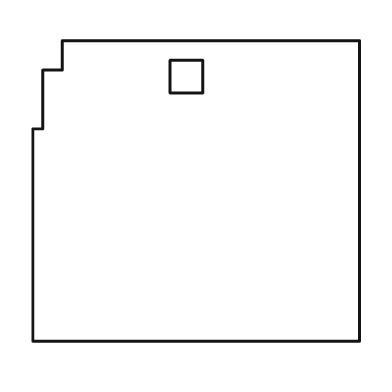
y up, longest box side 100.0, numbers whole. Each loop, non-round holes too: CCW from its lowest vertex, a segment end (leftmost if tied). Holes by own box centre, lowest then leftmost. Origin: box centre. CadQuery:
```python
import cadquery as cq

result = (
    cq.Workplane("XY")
    .moveTo(-50.0, -46.0)
    .lineTo(50.0, -46.0)
    .lineTo(50.0, 46.0)
    .lineTo(-41.0, 46.0)
    .lineTo(-41.0, 37.0)
    .lineTo(-47.0, 37.0)
    .lineTo(-47.0, 19.0)
    .lineTo(-50.0, 19.0)
    .close()
    .moveTo(-8.0, 30.0)
    .lineTo(2.0, 30.0)
    .lineTo(2.0, 40.0)
    .lineTo(-8.0, 40.0)
    .close()
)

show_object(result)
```